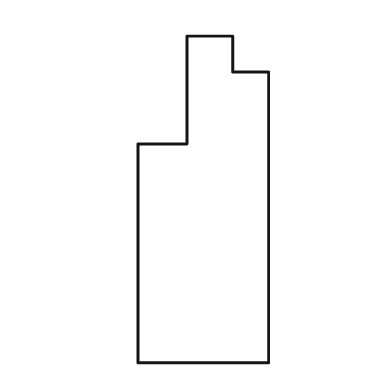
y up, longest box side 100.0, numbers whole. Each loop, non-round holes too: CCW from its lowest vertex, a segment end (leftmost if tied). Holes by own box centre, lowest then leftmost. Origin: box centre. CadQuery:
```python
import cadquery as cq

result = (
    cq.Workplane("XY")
    .moveTo(-20.0, -50.0)
    .lineTo(20.0, -50.0)
    .lineTo(20.0, 39.0)
    .lineTo(9.0, 39.0)
    .lineTo(9.0, 50.0)
    .lineTo(-5.0, 50.0)
    .lineTo(-5.0, 17.0)
    .lineTo(-20.0, 17.0)
    .close()
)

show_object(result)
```